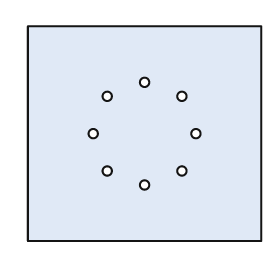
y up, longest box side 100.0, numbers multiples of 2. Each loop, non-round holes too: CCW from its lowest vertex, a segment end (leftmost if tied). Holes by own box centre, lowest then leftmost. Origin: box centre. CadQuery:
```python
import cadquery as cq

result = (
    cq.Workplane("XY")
    .moveTo(-50.0, -46.0)
    .lineTo(50.0, -46.0)
    .lineTo(50.0, 46.0)
    .lineTo(-50.0, 46.0)
    .close()
    .moveTo(0.0, -22.0)
    .circle(2.0)
    .moveTo(-16.0, -16.0)
    .circle(2.0)
    .moveTo(16.0, -16.0)
    .circle(2.0)
    .moveTo(-22.0, 0.0)
    .circle(2.0)
    .moveTo(22.0, 0.0)
    .circle(2.0)
    .moveTo(-16.0, 16.0)
    .circle(2.0)
    .moveTo(16.0, 16.0)
    .circle(2.0)
    .moveTo(0.0, 22.0)
    .circle(2.0)
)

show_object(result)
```